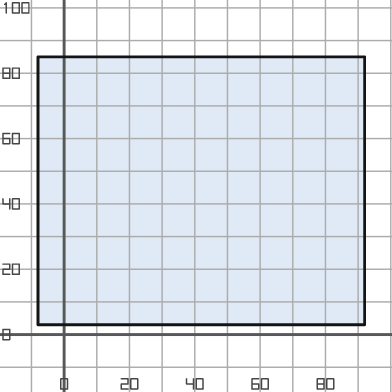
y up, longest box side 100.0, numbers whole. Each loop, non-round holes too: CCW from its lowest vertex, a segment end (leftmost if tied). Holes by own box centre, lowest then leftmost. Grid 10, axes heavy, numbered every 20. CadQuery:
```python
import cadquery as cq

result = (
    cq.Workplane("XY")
    .moveTo(-8.0, 3.0)
    .lineTo(92.0, 3.0)
    .lineTo(92.0, 85.0)
    .lineTo(-8.0, 85.0)
    .close()
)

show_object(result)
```